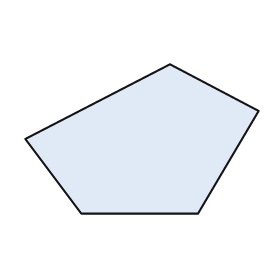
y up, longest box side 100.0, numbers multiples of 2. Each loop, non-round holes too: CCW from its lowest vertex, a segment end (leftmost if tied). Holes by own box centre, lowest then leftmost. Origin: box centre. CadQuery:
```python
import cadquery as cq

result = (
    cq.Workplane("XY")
    .moveTo(-26.0, -32.0)
    .lineTo(24.0, -32.0)
    .lineTo(50.0, 12.0)
    .lineTo(12.0, 32.0)
    .lineTo(-50.0, 0.0)
    .close()
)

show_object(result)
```